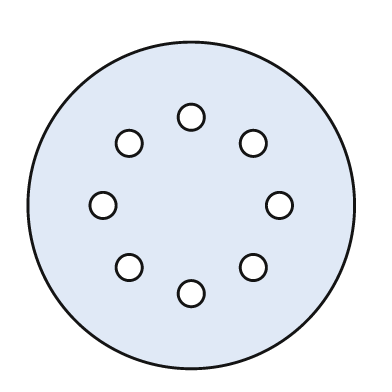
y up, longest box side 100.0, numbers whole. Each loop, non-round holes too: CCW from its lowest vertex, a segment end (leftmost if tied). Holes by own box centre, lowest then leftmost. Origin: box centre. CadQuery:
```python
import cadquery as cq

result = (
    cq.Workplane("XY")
    .moveTo(0.0, 0.0)
    .circle(50.0)
    .moveTo(0.0, -27.0)
    .circle(4.0)
    .moveTo(-19.0, -19.0)
    .circle(4.0)
    .moveTo(19.0, -19.0)
    .circle(4.0)
    .moveTo(-27.0, 0.0)
    .circle(4.0)
    .moveTo(27.0, 0.0)
    .circle(4.0)
    .moveTo(-19.0, 19.0)
    .circle(4.0)
    .moveTo(19.0, 19.0)
    .circle(4.0)
    .moveTo(0.0, 27.0)
    .circle(4.0)
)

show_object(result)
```